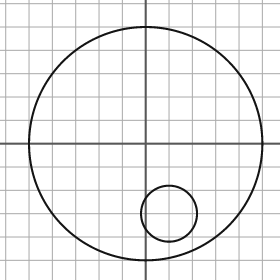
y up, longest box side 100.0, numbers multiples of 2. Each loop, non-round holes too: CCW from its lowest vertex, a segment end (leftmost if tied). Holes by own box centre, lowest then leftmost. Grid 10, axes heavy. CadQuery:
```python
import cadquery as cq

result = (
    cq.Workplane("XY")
    .moveTo(0.0, 0.0)
    .circle(50.0)
    .moveTo(10.0, -30.0)
    .circle(12.0)
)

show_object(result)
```